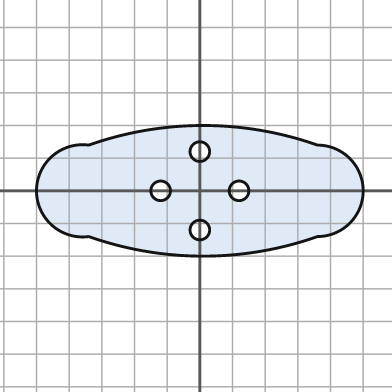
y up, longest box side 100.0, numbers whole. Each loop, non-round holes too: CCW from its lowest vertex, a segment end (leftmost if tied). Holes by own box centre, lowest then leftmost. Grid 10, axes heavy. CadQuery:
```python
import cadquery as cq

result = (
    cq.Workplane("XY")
    .moveTo(-34.0, -14.0)
    .threePointArc((1.0, -20.0), (36.0, -14.0))
    .threePointArc((50.0, 0.0), (36.0, 14.0))
    .threePointArc((1.0, 20.0), (-34.0, 14.0))
    .threePointArc((-50.0, 0.0), (-34.0, -14.0))
    .close()
    .moveTo(0.0, -12.0)
    .circle(3.0)
    .moveTo(-12.0, 0.0)
    .circle(3.0)
    .moveTo(12.0, 0.0)
    .circle(3.0)
    .moveTo(0.0, 12.0)
    .circle(3.0)
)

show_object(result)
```